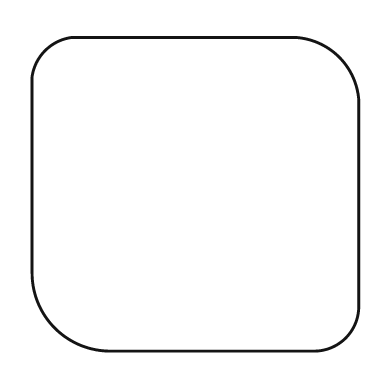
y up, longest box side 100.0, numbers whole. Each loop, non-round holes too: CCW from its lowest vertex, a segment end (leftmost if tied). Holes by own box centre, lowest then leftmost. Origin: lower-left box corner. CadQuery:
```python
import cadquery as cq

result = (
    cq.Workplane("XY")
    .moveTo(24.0, 0.0)
    .lineTo(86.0, 0.0)
    .threePointArc((96.0, 4.0), (100.0, 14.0))
    .lineTo(100.0, 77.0)
    .threePointArc((94.0, 90.0), (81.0, 96.0))
    .lineTo(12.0, 96.0)
    .threePointArc((4.0, 92.0), (0.0, 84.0))
    .lineTo(0.0, 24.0)
    .threePointArc((7.0, 7.0), (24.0, 0.0))
    .close()
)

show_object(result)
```